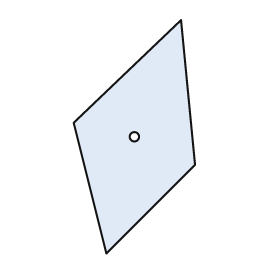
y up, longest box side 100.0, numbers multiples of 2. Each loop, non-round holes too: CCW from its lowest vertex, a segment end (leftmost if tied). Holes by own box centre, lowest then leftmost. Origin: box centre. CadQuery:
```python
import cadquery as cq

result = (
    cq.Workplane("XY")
    .moveTo(-12.0, -50.0)
    .lineTo(26.0, -12.0)
    .lineTo(20.0, 50.0)
    .lineTo(-26.0, 6.0)
    .close()
    .moveTo(0.0, 0.0)
    .circle(2.0)
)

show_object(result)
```